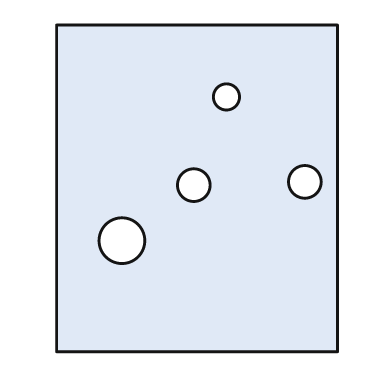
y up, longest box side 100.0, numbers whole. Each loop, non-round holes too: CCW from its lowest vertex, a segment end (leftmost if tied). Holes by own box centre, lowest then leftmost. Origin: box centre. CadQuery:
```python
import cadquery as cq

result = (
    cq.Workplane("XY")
    .moveTo(-43.0, -50.0)
    .lineTo(43.0, -50.0)
    .lineTo(43.0, 50.0)
    .lineTo(-43.0, 50.0)
    .close()
    .moveTo(-23.0, -16.0)
    .circle(7.0)
    .moveTo(-1.0, 1.0)
    .circle(5.0)
    .moveTo(33.0, 2.0)
    .circle(5.0)
    .moveTo(9.0, 28.0)
    .circle(4.0)
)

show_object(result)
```